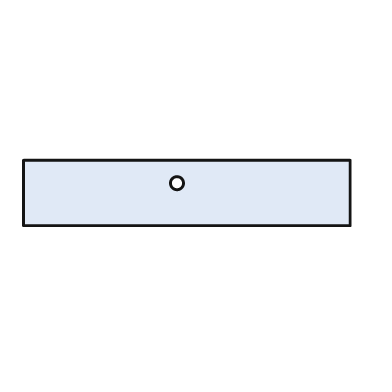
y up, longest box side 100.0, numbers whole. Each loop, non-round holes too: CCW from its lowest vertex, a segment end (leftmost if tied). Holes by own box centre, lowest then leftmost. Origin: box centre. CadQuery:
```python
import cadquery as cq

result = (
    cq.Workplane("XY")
    .moveTo(-50.0, -10.0)
    .lineTo(50.0, -10.0)
    .lineTo(50.0, 10.0)
    .lineTo(-50.0, 10.0)
    .close()
    .moveTo(-3.0, 3.0)
    .circle(2.0)
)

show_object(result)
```